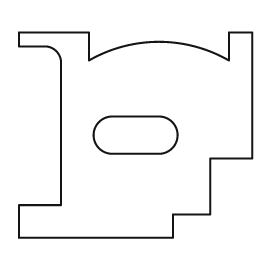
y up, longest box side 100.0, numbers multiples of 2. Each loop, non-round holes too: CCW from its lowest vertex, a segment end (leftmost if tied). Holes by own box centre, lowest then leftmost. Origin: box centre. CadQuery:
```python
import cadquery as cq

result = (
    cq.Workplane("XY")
    .moveTo(-50.0, -44.0)
    .lineTo(16.0, -44.0)
    .lineTo(16.0, -34.0)
    .lineTo(32.0, -34.0)
    .lineTo(32.0, -10.0)
    .lineTo(50.0, -10.0)
    .lineTo(50.0, 44.0)
    .lineTo(40.0, 44.0)
    .lineTo(40.0, 32.0)
    .threePointArc((10.0, 40.0), (-20.0, 32.0))
    .lineTo(-20.0, 44.0)
    .lineTo(-50.0, 44.0)
    .lineTo(-50.0, 38.0)
    .lineTo(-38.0, 38.0)
    .threePointArc((-34.0, 36.0), (-32.0, 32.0))
    .lineTo(-32.0, -30.0)
    .lineTo(-50.0, -30.0)
    .close()
    .moveTo(-10.0, -8.0)
    .lineTo(10.0, -8.0)
    .threePointArc((18.0, 0.0), (10.0, 8.0))
    .lineTo(-10.0, 8.0)
    .threePointArc((-18.0, 0.0), (-10.0, -8.0))
    .close()
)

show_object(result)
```